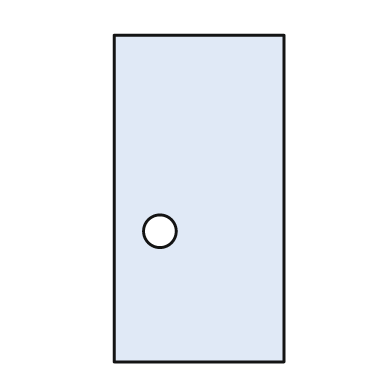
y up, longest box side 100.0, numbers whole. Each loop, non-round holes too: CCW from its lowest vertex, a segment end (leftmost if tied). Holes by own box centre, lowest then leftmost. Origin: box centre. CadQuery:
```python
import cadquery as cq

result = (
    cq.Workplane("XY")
    .moveTo(-26.0, -50.0)
    .lineTo(26.0, -50.0)
    .lineTo(26.0, 50.0)
    .lineTo(-26.0, 50.0)
    .close()
    .moveTo(-12.0, -10.0)
    .circle(5.0)
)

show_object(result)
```